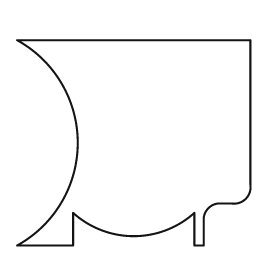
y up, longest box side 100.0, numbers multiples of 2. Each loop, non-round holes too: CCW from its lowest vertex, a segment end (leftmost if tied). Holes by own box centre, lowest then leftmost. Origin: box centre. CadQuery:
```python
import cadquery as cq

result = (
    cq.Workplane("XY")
    .moveTo(-50.0, -44.0)
    .lineTo(-26.0, -44.0)
    .lineTo(-26.0, -30.0)
    .threePointArc((0.0, -40.0), (26.0, -30.0))
    .lineTo(26.0, -44.0)
    .lineTo(30.0, -44.0)
    .lineTo(30.0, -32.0)
    .threePointArc((32.0, -28.0), (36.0, -26.0))
    .lineTo(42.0, -26.0)
    .threePointArc((48.0, -24.0), (50.0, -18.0))
    .lineTo(50.0, 44.0)
    .lineTo(-50.0, 44.0)
    .threePointArc((-24.0, 0.0), (-50.0, -44.0))
    .close()
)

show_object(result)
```